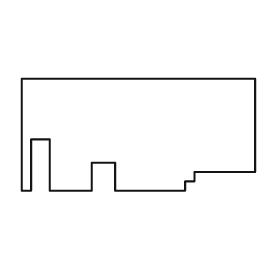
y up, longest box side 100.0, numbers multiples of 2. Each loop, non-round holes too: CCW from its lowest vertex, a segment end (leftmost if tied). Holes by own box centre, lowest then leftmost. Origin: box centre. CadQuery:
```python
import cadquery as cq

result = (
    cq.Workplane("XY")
    .moveTo(-50.0, -24.0)
    .lineTo(-46.0, -24.0)
    .lineTo(-46.0, -2.0)
    .lineTo(-38.0, -2.0)
    .lineTo(-38.0, -24.0)
    .lineTo(-20.0, -24.0)
    .lineTo(-20.0, -12.0)
    .lineTo(-10.0, -12.0)
    .lineTo(-10.0, -24.0)
    .lineTo(20.0, -24.0)
    .lineTo(20.0, -20.0)
    .lineTo(24.0, -20.0)
    .lineTo(24.0, -16.0)
    .lineTo(50.0, -16.0)
    .lineTo(50.0, 24.0)
    .lineTo(-50.0, 24.0)
    .close()
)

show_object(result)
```